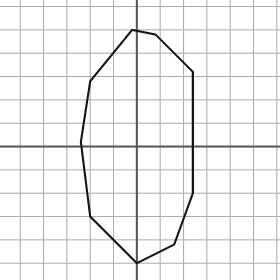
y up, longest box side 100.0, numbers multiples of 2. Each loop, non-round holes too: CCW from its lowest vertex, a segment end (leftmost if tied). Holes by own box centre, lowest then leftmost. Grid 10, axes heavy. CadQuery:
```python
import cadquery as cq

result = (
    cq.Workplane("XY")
    .moveTo(0.0, -50.0)
    .lineTo(16.0, -42.0)
    .lineTo(24.0, -20.0)
    .lineTo(24.0, 32.0)
    .lineTo(8.0, 48.0)
    .lineTo(-2.0, 50.0)
    .lineTo(-20.0, 28.0)
    .lineTo(-24.0, 2.0)
    .lineTo(-20.0, -30.0)
    .close()
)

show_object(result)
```